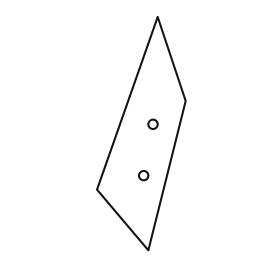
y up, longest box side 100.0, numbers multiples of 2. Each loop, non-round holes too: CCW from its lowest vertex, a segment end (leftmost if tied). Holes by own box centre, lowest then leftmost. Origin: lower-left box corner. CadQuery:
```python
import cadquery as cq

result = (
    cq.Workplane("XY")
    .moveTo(22.0, 0.0)
    .lineTo(38.0, 64.0)
    .lineTo(26.0, 100.0)
    .lineTo(0.0, 26.0)
    .close()
    .moveTo(20.0, 32.0)
    .circle(2.0)
    .moveTo(24.0, 54.0)
    .circle(2.0)
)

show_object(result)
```